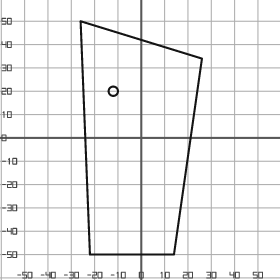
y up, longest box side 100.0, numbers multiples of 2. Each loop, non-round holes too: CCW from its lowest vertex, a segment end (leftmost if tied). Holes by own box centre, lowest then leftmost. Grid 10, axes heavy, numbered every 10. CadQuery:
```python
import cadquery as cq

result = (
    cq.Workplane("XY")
    .moveTo(-22.0, -50.0)
    .lineTo(14.0, -50.0)
    .lineTo(26.0, 34.0)
    .lineTo(-26.0, 50.0)
    .close()
    .moveTo(-12.0, 20.0)
    .circle(2.0)
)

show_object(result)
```